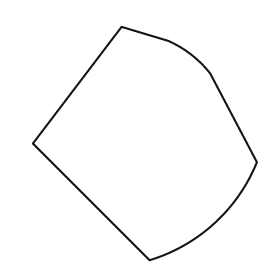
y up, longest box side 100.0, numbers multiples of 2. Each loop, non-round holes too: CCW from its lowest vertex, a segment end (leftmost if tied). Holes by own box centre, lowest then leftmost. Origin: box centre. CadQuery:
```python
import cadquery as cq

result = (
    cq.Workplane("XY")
    .moveTo(2.0, -50.0)
    .threePointArc((30.0, -34.0), (48.0, -8.0))
    .lineTo(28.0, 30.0)
    .threePointArc((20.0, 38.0), (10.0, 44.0))
    .lineTo(-10.0, 50.0)
    .lineTo(-48.0, 0.0)
    .close()
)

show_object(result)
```